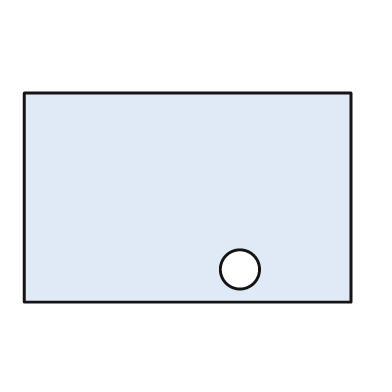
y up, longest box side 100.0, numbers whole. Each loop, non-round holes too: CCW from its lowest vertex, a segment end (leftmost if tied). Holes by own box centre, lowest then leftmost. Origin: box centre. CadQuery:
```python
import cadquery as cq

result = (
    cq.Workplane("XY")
    .moveTo(-50.0, -32.0)
    .lineTo(50.0, -32.0)
    .lineTo(50.0, 32.0)
    .lineTo(-50.0, 32.0)
    .close()
    .moveTo(16.0, -22.0)
    .circle(6.0)
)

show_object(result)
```